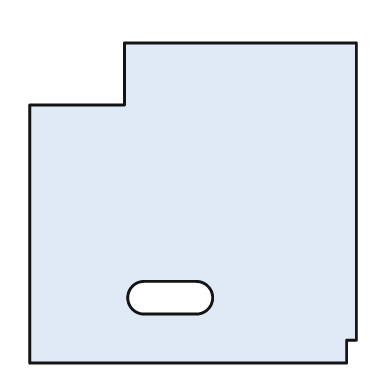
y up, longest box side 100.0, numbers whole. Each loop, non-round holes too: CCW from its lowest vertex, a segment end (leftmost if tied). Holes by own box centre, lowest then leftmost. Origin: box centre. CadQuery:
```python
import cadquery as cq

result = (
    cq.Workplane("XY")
    .moveTo(-50.0, -49.0)
    .lineTo(47.0, -49.0)
    .lineTo(47.0, -42.0)
    .lineTo(50.0, -42.0)
    .lineTo(50.0, 49.0)
    .lineTo(-21.0, 49.0)
    .lineTo(-21.0, 30.0)
    .lineTo(-50.0, 30.0)
    .close()
    .moveTo(-15.0, -34.0)
    .lineTo(1.0, -34.0)
    .threePointArc((6.0, -29.0), (1.0, -24.0))
    .lineTo(-15.0, -24.0)
    .threePointArc((-20.0, -29.0), (-15.0, -34.0))
    .close()
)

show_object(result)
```